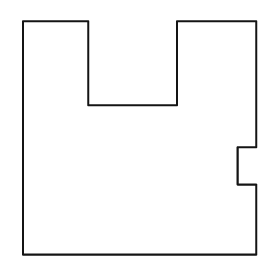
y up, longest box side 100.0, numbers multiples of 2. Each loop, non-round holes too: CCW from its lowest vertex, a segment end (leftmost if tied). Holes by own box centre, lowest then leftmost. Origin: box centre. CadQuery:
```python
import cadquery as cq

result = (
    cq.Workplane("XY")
    .moveTo(-50.0, -50.0)
    .lineTo(50.0, -50.0)
    .lineTo(50.0, -20.0)
    .lineTo(42.0, -20.0)
    .lineTo(42.0, -4.0)
    .lineTo(50.0, -4.0)
    .lineTo(50.0, 50.0)
    .lineTo(16.0, 50.0)
    .lineTo(16.0, 14.0)
    .lineTo(-22.0, 14.0)
    .lineTo(-22.0, 50.0)
    .lineTo(-50.0, 50.0)
    .close()
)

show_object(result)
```